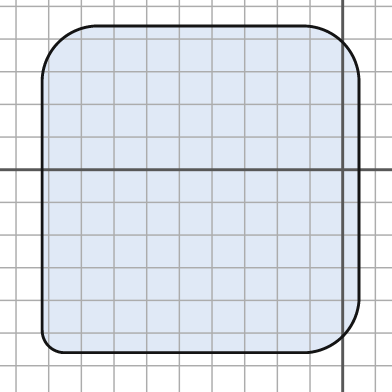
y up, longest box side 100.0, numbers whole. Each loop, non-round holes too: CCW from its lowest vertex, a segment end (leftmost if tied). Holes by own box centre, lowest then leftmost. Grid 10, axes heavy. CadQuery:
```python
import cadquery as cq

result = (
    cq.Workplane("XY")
    .moveTo(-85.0, -56.0)
    .lineTo(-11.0, -56.0)
    .threePointArc((0.0, -51.0), (5.0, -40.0))
    .lineTo(5.0, 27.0)
    .threePointArc((0.0, 39.0), (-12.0, 44.0))
    .lineTo(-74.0, 44.0)
    .threePointArc((-87.0, 39.0), (-92.0, 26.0))
    .lineTo(-92.0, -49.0)
    .threePointArc((-90.0, -54.0), (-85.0, -56.0))
    .close()
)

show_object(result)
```